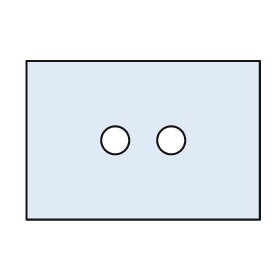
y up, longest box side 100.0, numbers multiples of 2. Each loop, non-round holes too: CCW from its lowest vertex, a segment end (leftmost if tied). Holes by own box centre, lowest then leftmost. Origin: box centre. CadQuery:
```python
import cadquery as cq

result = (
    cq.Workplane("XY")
    .moveTo(-50.0, -34.0)
    .lineTo(50.0, -34.0)
    .lineTo(50.0, 34.0)
    .lineTo(-50.0, 34.0)
    .close()
    .moveTo(-12.0, 0.0)
    .circle(6.0)
    .moveTo(12.0, 0.0)
    .circle(6.0)
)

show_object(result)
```